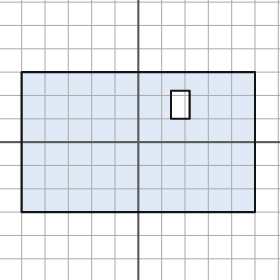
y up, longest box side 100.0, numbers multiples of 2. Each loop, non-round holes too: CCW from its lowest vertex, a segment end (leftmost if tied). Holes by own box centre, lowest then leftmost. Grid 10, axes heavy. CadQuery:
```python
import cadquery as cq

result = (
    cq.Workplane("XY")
    .moveTo(-50.0, -30.0)
    .lineTo(50.0, -30.0)
    .lineTo(50.0, 30.0)
    .lineTo(-50.0, 30.0)
    .close()
    .moveTo(14.0, 10.0)
    .lineTo(22.0, 10.0)
    .lineTo(22.0, 22.0)
    .lineTo(14.0, 22.0)
    .close()
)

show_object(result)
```